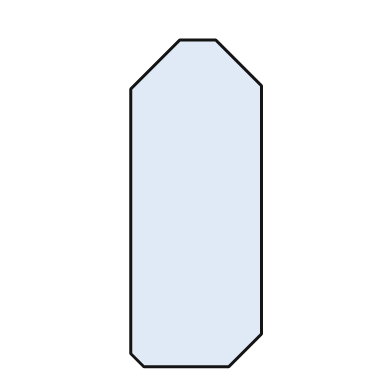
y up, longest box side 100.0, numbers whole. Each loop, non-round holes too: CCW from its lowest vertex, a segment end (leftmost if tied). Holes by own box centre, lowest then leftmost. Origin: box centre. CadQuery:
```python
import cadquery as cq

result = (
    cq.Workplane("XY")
    .moveTo(-16.0, -50.0)
    .lineTo(10.0, -50.0)
    .lineTo(20.0, -40.0)
    .lineTo(20.0, 36.0)
    .lineTo(6.0, 50.0)
    .lineTo(-5.0, 50.0)
    .lineTo(-20.0, 35.0)
    .lineTo(-20.0, -46.0)
    .close()
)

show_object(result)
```